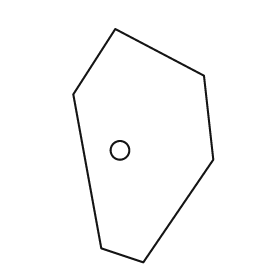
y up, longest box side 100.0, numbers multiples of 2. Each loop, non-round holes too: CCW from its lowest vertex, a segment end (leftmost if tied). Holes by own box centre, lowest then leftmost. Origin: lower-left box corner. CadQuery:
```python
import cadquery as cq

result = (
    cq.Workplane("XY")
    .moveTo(30.0, 0.0)
    .lineTo(60.0, 44.0)
    .lineTo(56.0, 80.0)
    .lineTo(18.0, 100.0)
    .lineTo(0.0, 72.0)
    .lineTo(12.0, 6.0)
    .close()
    .moveTo(20.0, 48.0)
    .circle(4.0)
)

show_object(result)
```